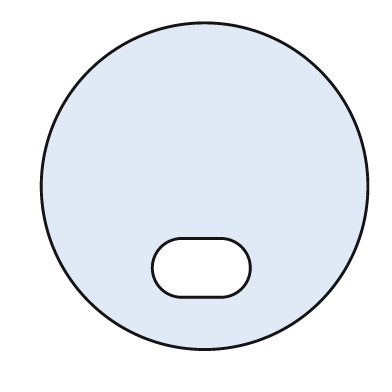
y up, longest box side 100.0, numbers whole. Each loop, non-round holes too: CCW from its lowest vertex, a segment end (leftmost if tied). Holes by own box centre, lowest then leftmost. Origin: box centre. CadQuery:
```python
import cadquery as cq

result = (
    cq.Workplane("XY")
    .moveTo(0.0, 0.0)
    .circle(50.0)
    .moveTo(-7.0, -34.0)
    .lineTo(5.0, -34.0)
    .threePointArc((14.0, -25.0), (5.0, -16.0))
    .lineTo(-7.0, -16.0)
    .threePointArc((-16.0, -25.0), (-7.0, -34.0))
    .close()
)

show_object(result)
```